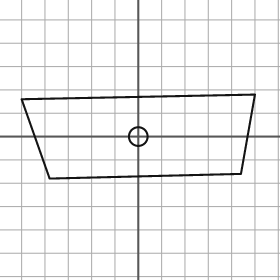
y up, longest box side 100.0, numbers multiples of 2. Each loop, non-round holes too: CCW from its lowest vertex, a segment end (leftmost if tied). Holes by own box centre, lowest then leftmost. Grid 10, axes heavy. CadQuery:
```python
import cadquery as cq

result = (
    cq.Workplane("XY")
    .moveTo(-38.0, -18.0)
    .lineTo(44.0, -16.0)
    .lineTo(50.0, 18.0)
    .lineTo(-50.0, 16.0)
    .close()
    .moveTo(0.0, 0.0)
    .circle(4.0)
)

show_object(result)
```